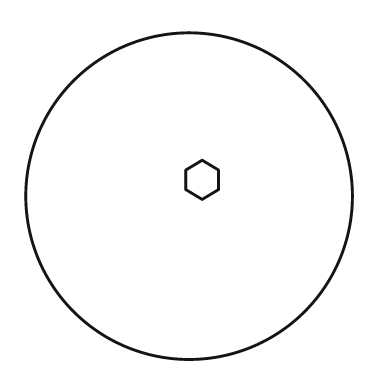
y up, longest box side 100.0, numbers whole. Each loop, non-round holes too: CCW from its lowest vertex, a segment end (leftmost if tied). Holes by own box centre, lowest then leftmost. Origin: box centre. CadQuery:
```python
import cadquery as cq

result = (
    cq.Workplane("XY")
    .moveTo(0.0, 0.0)
    .circle(50.0)
    .moveTo(4.0, -1.0)
    .lineTo(9.0, 2.0)
    .lineTo(9.0, 8.0)
    .lineTo(4.0, 11.0)
    .lineTo(-1.0, 8.0)
    .lineTo(-1.0, 2.0)
    .close()
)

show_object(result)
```